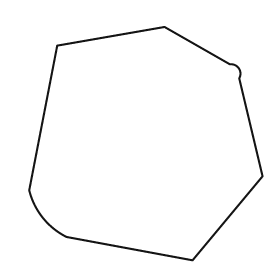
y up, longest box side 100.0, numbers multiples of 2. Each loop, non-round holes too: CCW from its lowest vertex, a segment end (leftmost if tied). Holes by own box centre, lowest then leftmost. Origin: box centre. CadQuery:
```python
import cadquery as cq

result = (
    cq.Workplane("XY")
    .moveTo(20.0, -50.0)
    .lineTo(50.0, -14.0)
    .lineTo(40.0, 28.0)
    .threePointArc((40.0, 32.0), (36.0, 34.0))
    .lineTo(8.0, 50.0)
    .lineTo(-38.0, 42.0)
    .lineTo(-50.0, -20.0)
    .threePointArc((-44.0, -32.0), (-34.0, -40.0))
    .close()
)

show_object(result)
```